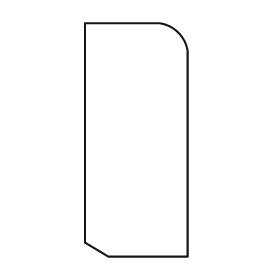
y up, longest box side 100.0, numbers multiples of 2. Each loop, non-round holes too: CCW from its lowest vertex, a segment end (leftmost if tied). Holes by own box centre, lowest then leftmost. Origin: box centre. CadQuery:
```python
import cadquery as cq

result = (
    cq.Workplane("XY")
    .moveTo(-12.0, -50.0)
    .lineTo(22.0, -50.0)
    .lineTo(22.0, 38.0)
    .threePointArc((18.0, 46.0), (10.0, 50.0))
    .lineTo(-22.0, 50.0)
    .lineTo(-22.0, -44.0)
    .close()
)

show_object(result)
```